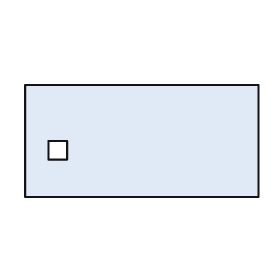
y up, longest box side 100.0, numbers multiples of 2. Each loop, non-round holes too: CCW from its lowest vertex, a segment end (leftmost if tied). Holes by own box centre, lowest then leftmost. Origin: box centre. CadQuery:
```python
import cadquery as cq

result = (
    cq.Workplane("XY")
    .moveTo(-50.0, -24.0)
    .lineTo(50.0, -24.0)
    .lineTo(50.0, 24.0)
    .lineTo(-50.0, 24.0)
    .close()
    .moveTo(-40.0, -8.0)
    .lineTo(-32.0, -8.0)
    .lineTo(-32.0, 0.0)
    .lineTo(-40.0, 0.0)
    .close()
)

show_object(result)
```